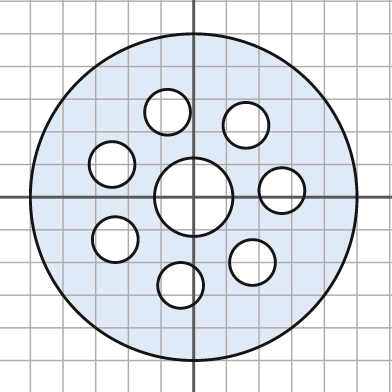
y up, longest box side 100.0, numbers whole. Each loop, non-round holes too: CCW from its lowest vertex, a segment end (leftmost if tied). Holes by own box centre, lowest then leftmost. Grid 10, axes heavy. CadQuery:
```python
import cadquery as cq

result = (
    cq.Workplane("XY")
    .moveTo(0.0, 0.0)
    .circle(50.0)
    .moveTo(-4.0, -27.0)
    .circle(7.0)
    .moveTo(18.0, -20.0)
    .circle(7.0)
    .moveTo(-24.0, -13.0)
    .circle(7.0)
    .moveTo(0.0, 0.0)
    .circle(12.0)
    .moveTo(27.0, 2.0)
    .circle(7.0)
    .moveTo(-25.0, 10.0)
    .circle(7.0)
    .moveTo(16.0, 22.0)
    .circle(7.0)
    .moveTo(-8.0, 26.0)
    .circle(7.0)
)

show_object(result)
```